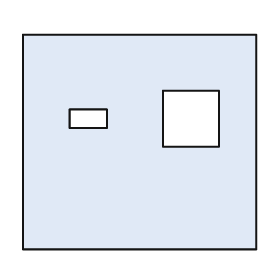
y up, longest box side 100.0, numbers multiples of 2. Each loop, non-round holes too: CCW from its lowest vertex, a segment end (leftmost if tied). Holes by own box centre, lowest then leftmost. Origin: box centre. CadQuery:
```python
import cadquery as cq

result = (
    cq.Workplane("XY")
    .moveTo(-50.0, -46.0)
    .lineTo(50.0, -46.0)
    .lineTo(50.0, 46.0)
    .lineTo(-50.0, 46.0)
    .close()
    .moveTo(-30.0, 6.0)
    .lineTo(-14.0, 6.0)
    .lineTo(-14.0, 14.0)
    .lineTo(-30.0, 14.0)
    .close()
    .moveTo(10.0, -2.0)
    .lineTo(34.0, -2.0)
    .lineTo(34.0, 22.0)
    .lineTo(10.0, 22.0)
    .close()
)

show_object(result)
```